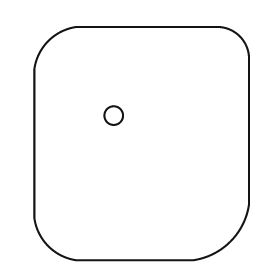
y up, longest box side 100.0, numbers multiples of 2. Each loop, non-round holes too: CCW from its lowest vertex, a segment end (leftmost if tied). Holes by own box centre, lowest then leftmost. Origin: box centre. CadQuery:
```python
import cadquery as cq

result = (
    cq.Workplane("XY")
    .moveTo(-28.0, -50.0)
    .lineTo(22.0, -50.0)
    .threePointArc((38.0, -42.0), (46.0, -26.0))
    .lineTo(46.0, 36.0)
    .threePointArc((42.0, 46.0), (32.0, 50.0))
    .lineTo(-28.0, 50.0)
    .threePointArc((-40.0, 44.0), (-46.0, 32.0))
    .lineTo(-46.0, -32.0)
    .threePointArc((-40.0, -44.0), (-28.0, -50.0))
    .close()
    .moveTo(-12.0, 12.0)
    .circle(4.0)
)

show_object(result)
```